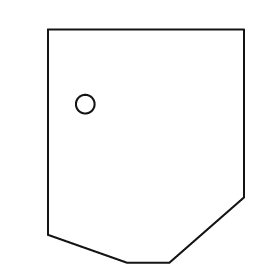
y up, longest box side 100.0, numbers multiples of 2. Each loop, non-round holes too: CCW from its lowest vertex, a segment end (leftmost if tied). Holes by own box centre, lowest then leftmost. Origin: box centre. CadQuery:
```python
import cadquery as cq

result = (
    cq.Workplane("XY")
    .moveTo(-8.0, -50.0)
    .lineTo(10.0, -50.0)
    .lineTo(42.0, -22.0)
    .lineTo(42.0, 50.0)
    .lineTo(-42.0, 50.0)
    .lineTo(-42.0, -38.0)
    .close()
    .moveTo(-26.0, 18.0)
    .circle(4.0)
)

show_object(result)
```